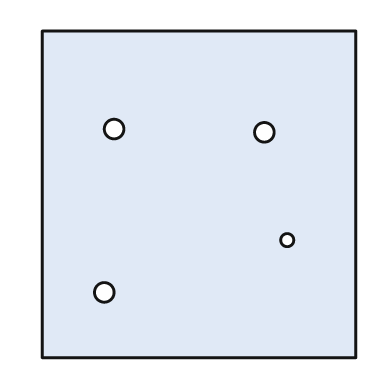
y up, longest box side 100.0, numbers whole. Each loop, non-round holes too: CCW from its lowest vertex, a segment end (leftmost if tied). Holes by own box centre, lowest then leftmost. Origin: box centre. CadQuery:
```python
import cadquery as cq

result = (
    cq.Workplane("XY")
    .moveTo(-48.0, -50.0)
    .lineTo(48.0, -50.0)
    .lineTo(48.0, 50.0)
    .lineTo(-48.0, 50.0)
    .close()
    .moveTo(-29.0, -30.0)
    .circle(3.0)
    .moveTo(27.0, -14.0)
    .circle(2.0)
    .moveTo(20.0, 19.0)
    .circle(3.0)
    .moveTo(-26.0, 20.0)
    .circle(3.0)
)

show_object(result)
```